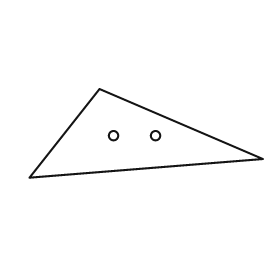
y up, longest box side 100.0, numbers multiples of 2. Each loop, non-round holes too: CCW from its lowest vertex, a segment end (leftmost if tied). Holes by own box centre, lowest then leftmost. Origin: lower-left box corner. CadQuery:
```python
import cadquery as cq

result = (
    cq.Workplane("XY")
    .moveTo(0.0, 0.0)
    .lineTo(100.0, 8.0)
    .lineTo(30.0, 38.0)
    .close()
    .moveTo(36.0, 18.0)
    .circle(2.0)
    .moveTo(54.0, 18.0)
    .circle(2.0)
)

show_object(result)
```